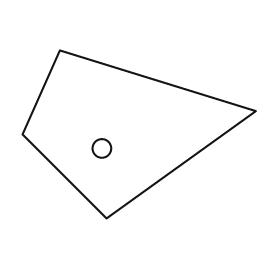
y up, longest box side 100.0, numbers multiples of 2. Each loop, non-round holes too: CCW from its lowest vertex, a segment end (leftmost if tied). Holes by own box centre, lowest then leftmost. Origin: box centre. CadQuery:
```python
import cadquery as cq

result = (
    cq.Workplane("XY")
    .moveTo(-14.0, -36.0)
    .lineTo(50.0, 10.0)
    .lineTo(-34.0, 36.0)
    .lineTo(-50.0, 0.0)
    .close()
    .moveTo(-16.0, -6.0)
    .circle(4.0)
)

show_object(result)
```